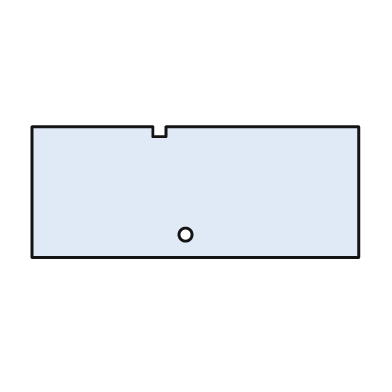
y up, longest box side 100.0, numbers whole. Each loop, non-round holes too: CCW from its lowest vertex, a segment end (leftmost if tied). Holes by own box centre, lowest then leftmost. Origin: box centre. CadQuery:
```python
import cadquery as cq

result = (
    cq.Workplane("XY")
    .moveTo(-50.0, -20.0)
    .lineTo(50.0, -20.0)
    .lineTo(50.0, 20.0)
    .lineTo(-9.0, 20.0)
    .lineTo(-9.0, 17.0)
    .lineTo(-13.0, 17.0)
    .lineTo(-13.0, 20.0)
    .lineTo(-50.0, 20.0)
    .close()
    .moveTo(-3.0, -13.0)
    .circle(2.0)
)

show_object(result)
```